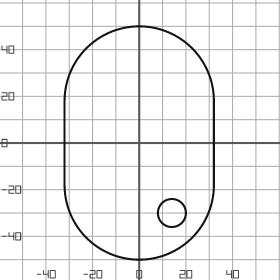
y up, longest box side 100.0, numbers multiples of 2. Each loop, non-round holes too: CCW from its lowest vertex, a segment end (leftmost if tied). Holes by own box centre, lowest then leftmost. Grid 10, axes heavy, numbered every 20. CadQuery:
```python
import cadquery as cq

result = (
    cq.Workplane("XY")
    .moveTo(-32.0, -18.0)
    .threePointArc((0.0, -50.0), (32.0, -18.0))
    .lineTo(32.0, 18.0)
    .threePointArc((0.0, 50.0), (-32.0, 18.0))
    .close()
    .moveTo(14.0, -30.0)
    .circle(6.0)
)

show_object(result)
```